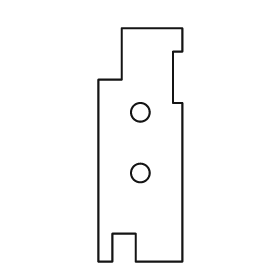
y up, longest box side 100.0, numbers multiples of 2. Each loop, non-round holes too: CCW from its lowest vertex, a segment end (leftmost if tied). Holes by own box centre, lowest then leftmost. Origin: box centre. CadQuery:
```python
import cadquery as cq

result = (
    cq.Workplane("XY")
    .moveTo(-18.0, -50.0)
    .lineTo(-12.0, -50.0)
    .lineTo(-12.0, -38.0)
    .lineTo(-2.0, -38.0)
    .lineTo(-2.0, -50.0)
    .lineTo(18.0, -50.0)
    .lineTo(18.0, 18.0)
    .lineTo(14.0, 18.0)
    .lineTo(14.0, 40.0)
    .lineTo(18.0, 40.0)
    .lineTo(18.0, 50.0)
    .lineTo(-8.0, 50.0)
    .lineTo(-8.0, 28.0)
    .lineTo(-18.0, 28.0)
    .close()
    .moveTo(0.0, -12.0)
    .circle(4.0)
    .moveTo(0.0, 14.0)
    .circle(4.0)
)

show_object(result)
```